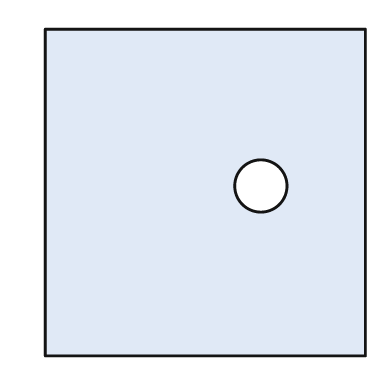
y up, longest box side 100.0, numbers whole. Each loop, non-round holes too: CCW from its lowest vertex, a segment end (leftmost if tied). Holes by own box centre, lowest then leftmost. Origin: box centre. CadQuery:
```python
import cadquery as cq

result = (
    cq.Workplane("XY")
    .moveTo(-49.0, -50.0)
    .lineTo(49.0, -50.0)
    .lineTo(49.0, 50.0)
    .lineTo(-49.0, 50.0)
    .close()
    .moveTo(17.0, 2.0)
    .circle(8.0)
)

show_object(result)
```